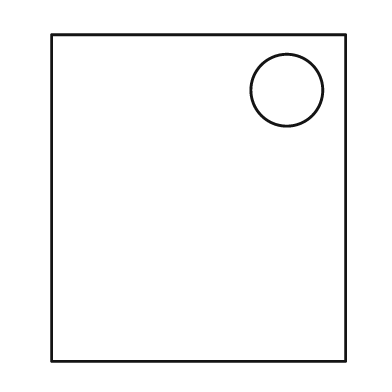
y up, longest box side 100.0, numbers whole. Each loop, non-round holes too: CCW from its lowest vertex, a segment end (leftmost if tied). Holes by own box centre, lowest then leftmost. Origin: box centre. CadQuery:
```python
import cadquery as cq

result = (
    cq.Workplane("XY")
    .moveTo(-45.0, -50.0)
    .lineTo(45.0, -50.0)
    .lineTo(45.0, 50.0)
    .lineTo(-45.0, 50.0)
    .close()
    .moveTo(27.0, 33.0)
    .circle(11.0)
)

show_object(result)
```